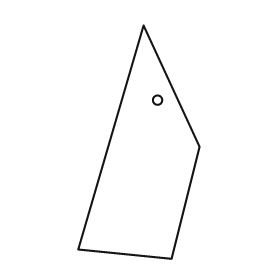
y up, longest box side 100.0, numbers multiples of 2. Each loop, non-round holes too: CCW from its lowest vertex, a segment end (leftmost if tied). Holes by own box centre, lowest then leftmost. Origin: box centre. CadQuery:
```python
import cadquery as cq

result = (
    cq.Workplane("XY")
    .moveTo(14.0, -50.0)
    .lineTo(26.0, -2.0)
    .lineTo(2.0, 50.0)
    .lineTo(-26.0, -46.0)
    .close()
    .moveTo(8.0, 18.0)
    .circle(2.0)
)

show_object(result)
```